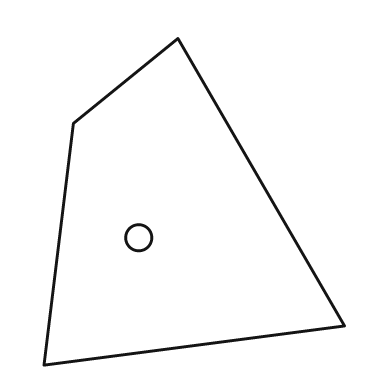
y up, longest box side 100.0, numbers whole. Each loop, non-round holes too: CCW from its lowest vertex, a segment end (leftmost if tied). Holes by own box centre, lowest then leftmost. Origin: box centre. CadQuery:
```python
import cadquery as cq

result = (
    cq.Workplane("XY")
    .moveTo(-46.0, -50.0)
    .lineTo(46.0, -38.0)
    .lineTo(-5.0, 50.0)
    .lineTo(-37.0, 24.0)
    .close()
    .moveTo(-17.0, -11.0)
    .circle(4.0)
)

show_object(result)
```